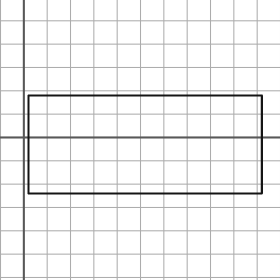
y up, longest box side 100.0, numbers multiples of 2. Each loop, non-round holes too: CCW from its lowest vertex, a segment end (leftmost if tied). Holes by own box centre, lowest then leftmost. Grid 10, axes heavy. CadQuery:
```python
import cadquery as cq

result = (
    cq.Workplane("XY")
    .moveTo(2.0, -24.0)
    .lineTo(102.0, -24.0)
    .lineTo(102.0, 18.0)
    .lineTo(2.0, 18.0)
    .close()
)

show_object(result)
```